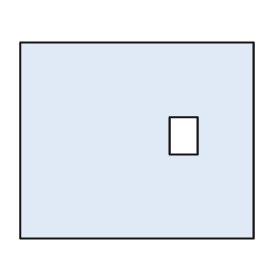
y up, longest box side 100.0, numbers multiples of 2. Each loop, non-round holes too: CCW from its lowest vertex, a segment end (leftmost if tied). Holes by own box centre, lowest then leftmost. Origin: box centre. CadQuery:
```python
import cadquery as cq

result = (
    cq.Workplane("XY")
    .moveTo(-50.0, -42.0)
    .lineTo(50.0, -42.0)
    .lineTo(50.0, 42.0)
    .lineTo(-50.0, 42.0)
    .close()
    .moveTo(14.0, -6.0)
    .lineTo(26.0, -6.0)
    .lineTo(26.0, 10.0)
    .lineTo(14.0, 10.0)
    .close()
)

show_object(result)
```